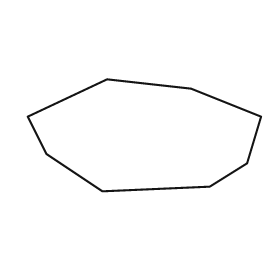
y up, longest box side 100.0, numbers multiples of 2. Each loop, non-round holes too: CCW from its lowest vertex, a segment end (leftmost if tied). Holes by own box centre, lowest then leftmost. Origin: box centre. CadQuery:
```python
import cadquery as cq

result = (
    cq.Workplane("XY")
    .moveTo(-18.0, -24.0)
    .lineTo(28.0, -22.0)
    .lineTo(44.0, -12.0)
    .lineTo(50.0, 8.0)
    .lineTo(20.0, 20.0)
    .lineTo(-16.0, 24.0)
    .lineTo(-50.0, 8.0)
    .lineTo(-42.0, -8.0)
    .close()
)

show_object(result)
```